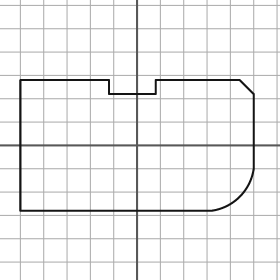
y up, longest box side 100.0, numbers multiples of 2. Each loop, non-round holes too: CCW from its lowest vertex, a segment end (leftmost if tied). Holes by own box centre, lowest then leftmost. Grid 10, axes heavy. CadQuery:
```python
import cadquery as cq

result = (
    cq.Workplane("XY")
    .moveTo(-50.0, -28.0)
    .lineTo(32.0, -28.0)
    .threePointArc((44.0, -22.0), (50.0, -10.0))
    .lineTo(50.0, 22.0)
    .lineTo(44.0, 28.0)
    .lineTo(8.0, 28.0)
    .lineTo(8.0, 22.0)
    .lineTo(-12.0, 22.0)
    .lineTo(-12.0, 28.0)
    .lineTo(-50.0, 28.0)
    .close()
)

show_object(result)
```